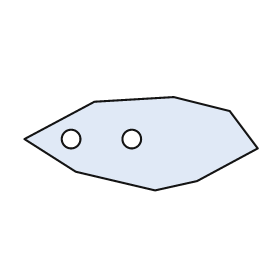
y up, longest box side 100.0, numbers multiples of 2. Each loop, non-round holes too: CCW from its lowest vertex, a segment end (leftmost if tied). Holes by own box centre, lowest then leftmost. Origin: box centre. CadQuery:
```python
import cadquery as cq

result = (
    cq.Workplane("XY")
    .moveTo(6.0, -20.0)
    .lineTo(24.0, -16.0)
    .lineTo(50.0, -2.0)
    .lineTo(38.0, 14.0)
    .lineTo(14.0, 20.0)
    .lineTo(-20.0, 18.0)
    .lineTo(-50.0, 2.0)
    .lineTo(-28.0, -12.0)
    .close()
    .moveTo(-30.0, 2.0)
    .circle(4.0)
    .moveTo(-4.0, 2.0)
    .circle(4.0)
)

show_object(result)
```